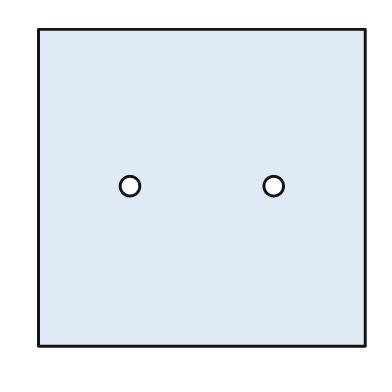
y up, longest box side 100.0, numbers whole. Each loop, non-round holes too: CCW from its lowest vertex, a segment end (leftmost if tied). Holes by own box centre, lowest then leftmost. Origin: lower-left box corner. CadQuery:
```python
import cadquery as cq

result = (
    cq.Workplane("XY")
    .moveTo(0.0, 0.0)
    .lineTo(100.0, 0.0)
    .lineTo(100.0, 97.0)
    .lineTo(0.0, 97.0)
    .close()
    .moveTo(28.0, 49.0)
    .circle(3.0)
    .moveTo(72.0, 49.0)
    .circle(3.0)
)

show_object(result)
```